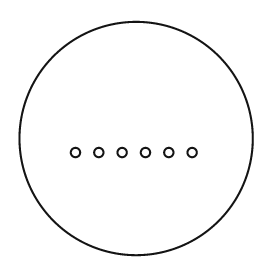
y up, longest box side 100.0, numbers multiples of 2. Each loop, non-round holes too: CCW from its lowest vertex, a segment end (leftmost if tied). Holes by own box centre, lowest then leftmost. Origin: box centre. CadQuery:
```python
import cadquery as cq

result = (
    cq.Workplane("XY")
    .moveTo(0.0, 0.0)
    .circle(50.0)
    .moveTo(-26.0, -6.0)
    .circle(2.0)
    .moveTo(-16.0, -6.0)
    .circle(2.0)
    .moveTo(-6.0, -6.0)
    .circle(2.0)
    .moveTo(4.0, -6.0)
    .circle(2.0)
    .moveTo(14.0, -6.0)
    .circle(2.0)
    .moveTo(24.0, -6.0)
    .circle(2.0)
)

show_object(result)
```